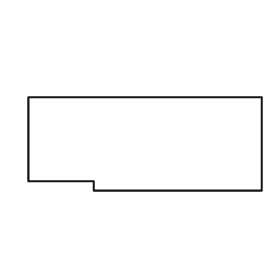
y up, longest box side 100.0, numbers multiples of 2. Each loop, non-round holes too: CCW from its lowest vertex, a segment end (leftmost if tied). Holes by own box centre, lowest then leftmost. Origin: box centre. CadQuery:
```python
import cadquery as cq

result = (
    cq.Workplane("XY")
    .moveTo(-22.0, -20.0)
    .lineTo(50.0, -20.0)
    .lineTo(50.0, 20.0)
    .lineTo(-50.0, 20.0)
    .lineTo(-50.0, -16.0)
    .lineTo(-22.0, -16.0)
    .close()
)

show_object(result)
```